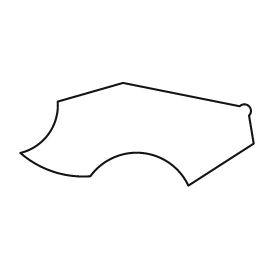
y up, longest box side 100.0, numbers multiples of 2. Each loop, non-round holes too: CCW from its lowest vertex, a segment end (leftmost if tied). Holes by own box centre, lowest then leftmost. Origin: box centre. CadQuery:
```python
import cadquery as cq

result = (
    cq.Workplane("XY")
    .moveTo(22.0, -22.0)
    .lineTo(50.0, -4.0)
    .lineTo(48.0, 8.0)
    .threePointArc((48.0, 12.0), (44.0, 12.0))
    .lineTo(-6.0, 22.0)
    .lineTo(-34.0, 14.0)
    .threePointArc((-38.0, 0.0), (-50.0, -8.0))
    .threePointArc((-36.0, -16.0), (-20.0, -18.0))
    .threePointArc((2.0, -8.0), (22.0, -22.0))
    .close()
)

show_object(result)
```